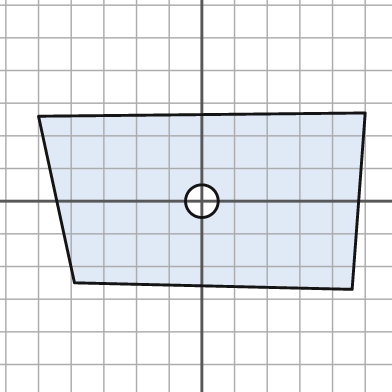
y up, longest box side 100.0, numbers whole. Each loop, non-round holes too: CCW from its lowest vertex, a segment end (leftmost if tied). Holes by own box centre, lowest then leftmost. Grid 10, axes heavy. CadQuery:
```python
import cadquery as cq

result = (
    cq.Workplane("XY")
    .moveTo(46.0, -27.0)
    .lineTo(50.0, 27.0)
    .lineTo(-50.0, 26.0)
    .lineTo(-39.0, -25.0)
    .close()
    .moveTo(0.0, 0.0)
    .circle(5.0)
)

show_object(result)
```